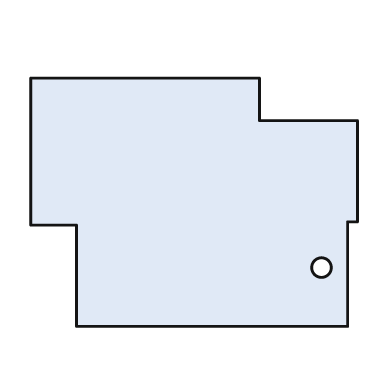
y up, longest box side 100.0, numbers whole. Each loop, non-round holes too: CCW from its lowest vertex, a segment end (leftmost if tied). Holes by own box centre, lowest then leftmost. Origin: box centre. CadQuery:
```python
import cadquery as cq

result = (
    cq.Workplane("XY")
    .moveTo(-36.0, -38.0)
    .lineTo(47.0, -38.0)
    .lineTo(47.0, -6.0)
    .lineTo(50.0, -6.0)
    .lineTo(50.0, 25.0)
    .lineTo(20.0, 25.0)
    .lineTo(20.0, 38.0)
    .lineTo(-50.0, 38.0)
    .lineTo(-50.0, -7.0)
    .lineTo(-36.0, -7.0)
    .close()
    .moveTo(39.0, -20.0)
    .circle(3.0)
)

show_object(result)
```